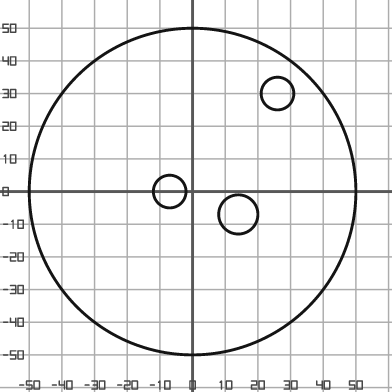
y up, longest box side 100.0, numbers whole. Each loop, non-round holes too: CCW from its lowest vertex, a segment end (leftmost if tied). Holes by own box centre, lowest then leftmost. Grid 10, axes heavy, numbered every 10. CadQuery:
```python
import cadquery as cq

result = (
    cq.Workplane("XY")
    .moveTo(0.0, 0.0)
    .circle(50.0)
    .moveTo(14.0, -7.0)
    .circle(6.0)
    .moveTo(-7.0, 0.0)
    .circle(5.0)
    .moveTo(26.0, 30.0)
    .circle(5.0)
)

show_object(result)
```